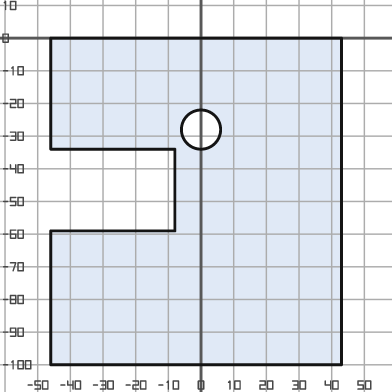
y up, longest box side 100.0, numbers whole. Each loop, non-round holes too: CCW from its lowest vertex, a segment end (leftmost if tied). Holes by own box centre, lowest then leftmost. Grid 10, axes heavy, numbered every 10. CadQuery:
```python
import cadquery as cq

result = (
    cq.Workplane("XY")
    .moveTo(-46.0, -100.0)
    .lineTo(43.0, -100.0)
    .lineTo(43.0, 0.0)
    .lineTo(-46.0, 0.0)
    .lineTo(-46.0, -34.0)
    .lineTo(-8.0, -34.0)
    .lineTo(-8.0, -59.0)
    .lineTo(-46.0, -59.0)
    .close()
    .moveTo(0.0, -28.0)
    .circle(6.0)
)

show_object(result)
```